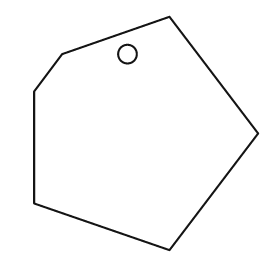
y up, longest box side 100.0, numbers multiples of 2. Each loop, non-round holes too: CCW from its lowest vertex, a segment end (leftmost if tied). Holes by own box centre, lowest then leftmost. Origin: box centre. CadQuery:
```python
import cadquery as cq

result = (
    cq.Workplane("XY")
    .moveTo(10.0, -50.0)
    .lineTo(48.0, 0.0)
    .lineTo(10.0, 50.0)
    .lineTo(-36.0, 34.0)
    .lineTo(-48.0, 18.0)
    .lineTo(-48.0, -30.0)
    .close()
    .moveTo(-8.0, 34.0)
    .circle(4.0)
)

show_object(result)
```